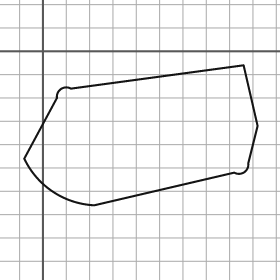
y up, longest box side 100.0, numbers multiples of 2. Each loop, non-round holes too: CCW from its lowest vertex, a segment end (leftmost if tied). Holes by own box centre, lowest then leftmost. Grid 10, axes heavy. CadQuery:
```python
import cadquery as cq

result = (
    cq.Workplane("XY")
    .moveTo(22.0, -66.0)
    .lineTo(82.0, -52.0)
    .threePointArc((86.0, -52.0), (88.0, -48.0))
    .lineTo(92.0, -32.0)
    .lineTo(86.0, -6.0)
    .lineTo(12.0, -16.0)
    .threePointArc((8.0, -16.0), (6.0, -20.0))
    .lineTo(-8.0, -46.0)
    .threePointArc((4.0, -60.0), (22.0, -66.0))
    .close()
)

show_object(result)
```